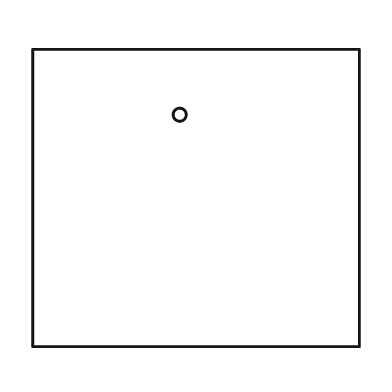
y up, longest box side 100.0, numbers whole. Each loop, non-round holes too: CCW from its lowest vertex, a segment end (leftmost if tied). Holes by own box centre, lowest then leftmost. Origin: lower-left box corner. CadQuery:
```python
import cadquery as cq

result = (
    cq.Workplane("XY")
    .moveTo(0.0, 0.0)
    .lineTo(100.0, 0.0)
    .lineTo(100.0, 91.0)
    .lineTo(0.0, 91.0)
    .close()
    .moveTo(45.0, 71.0)
    .circle(2.0)
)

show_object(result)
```